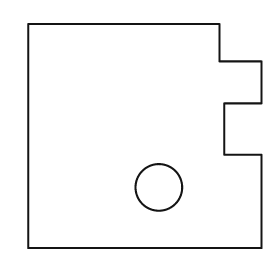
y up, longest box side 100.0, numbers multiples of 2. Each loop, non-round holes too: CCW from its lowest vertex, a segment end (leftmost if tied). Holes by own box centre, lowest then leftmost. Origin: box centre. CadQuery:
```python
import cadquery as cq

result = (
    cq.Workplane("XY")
    .moveTo(-50.0, -48.0)
    .lineTo(50.0, -48.0)
    .lineTo(50.0, -8.0)
    .lineTo(34.0, -8.0)
    .lineTo(34.0, 14.0)
    .lineTo(50.0, 14.0)
    .lineTo(50.0, 32.0)
    .lineTo(32.0, 32.0)
    .lineTo(32.0, 48.0)
    .lineTo(-50.0, 48.0)
    .close()
    .moveTo(6.0, -22.0)
    .circle(10.0)
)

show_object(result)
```